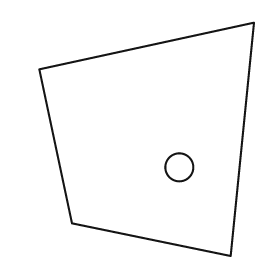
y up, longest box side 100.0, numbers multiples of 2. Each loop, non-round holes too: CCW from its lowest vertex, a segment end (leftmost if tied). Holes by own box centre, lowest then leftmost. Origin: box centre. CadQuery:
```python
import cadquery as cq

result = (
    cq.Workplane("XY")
    .moveTo(36.0, -50.0)
    .lineTo(46.0, 50.0)
    .lineTo(-46.0, 30.0)
    .lineTo(-32.0, -36.0)
    .close()
    .moveTo(14.0, -12.0)
    .circle(6.0)
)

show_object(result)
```